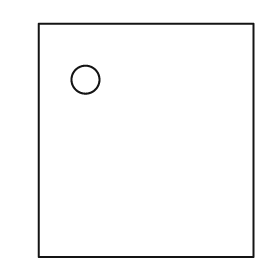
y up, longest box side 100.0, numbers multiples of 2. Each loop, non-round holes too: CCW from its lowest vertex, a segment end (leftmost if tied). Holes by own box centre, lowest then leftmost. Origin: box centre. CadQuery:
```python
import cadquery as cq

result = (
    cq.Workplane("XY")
    .moveTo(-46.0, -50.0)
    .lineTo(46.0, -50.0)
    .lineTo(46.0, 50.0)
    .lineTo(-46.0, 50.0)
    .close()
    .moveTo(-26.0, 26.0)
    .circle(6.0)
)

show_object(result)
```